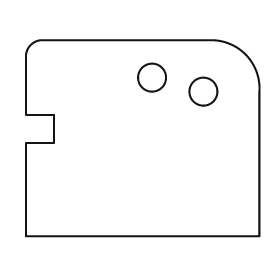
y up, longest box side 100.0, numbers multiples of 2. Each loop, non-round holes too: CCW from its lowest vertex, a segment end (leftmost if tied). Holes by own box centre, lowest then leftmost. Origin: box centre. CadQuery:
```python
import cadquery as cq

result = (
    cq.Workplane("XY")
    .moveTo(-50.0, -42.0)
    .lineTo(50.0, -42.0)
    .lineTo(50.0, 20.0)
    .threePointArc((44.0, 36.0), (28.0, 42.0))
    .lineTo(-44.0, 42.0)
    .threePointArc((-48.0, 40.0), (-50.0, 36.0))
    .lineTo(-50.0, 10.0)
    .lineTo(-38.0, 10.0)
    .lineTo(-38.0, -2.0)
    .lineTo(-50.0, -2.0)
    .close()
    .moveTo(26.0, 20.0)
    .circle(6.0)
    .moveTo(4.0, 26.0)
    .circle(6.0)
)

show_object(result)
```